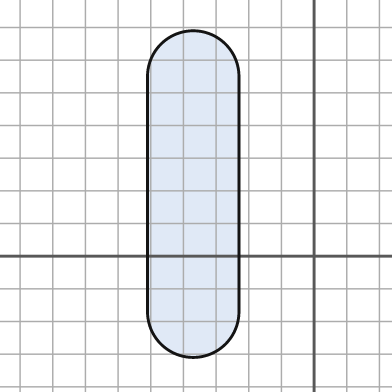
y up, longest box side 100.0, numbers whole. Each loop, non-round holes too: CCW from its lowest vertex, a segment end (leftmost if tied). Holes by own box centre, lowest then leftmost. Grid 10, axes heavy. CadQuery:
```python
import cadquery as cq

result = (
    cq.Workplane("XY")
    .moveTo(-51.0, -17.0)
    .threePointArc((-37.0, -31.0), (-23.0, -17.0))
    .lineTo(-23.0, 55.0)
    .threePointArc((-37.0, 69.0), (-51.0, 55.0))
    .close()
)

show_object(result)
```